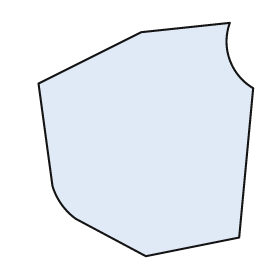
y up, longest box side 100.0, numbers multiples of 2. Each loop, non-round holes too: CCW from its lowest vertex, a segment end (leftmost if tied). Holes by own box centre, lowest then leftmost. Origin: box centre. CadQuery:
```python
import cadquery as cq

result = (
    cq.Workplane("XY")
    .moveTo(0.0, -50.0)
    .lineTo(40.0, -42.0)
    .lineTo(46.0, 22.0)
    .threePointArc((36.0, 34.0), (36.0, 50.0))
    .lineTo(-2.0, 46.0)
    .lineTo(-46.0, 24.0)
    .lineTo(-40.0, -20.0)
    .threePointArc((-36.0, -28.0), (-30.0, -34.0))
    .close()
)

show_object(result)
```